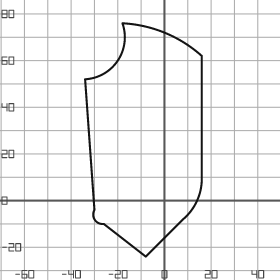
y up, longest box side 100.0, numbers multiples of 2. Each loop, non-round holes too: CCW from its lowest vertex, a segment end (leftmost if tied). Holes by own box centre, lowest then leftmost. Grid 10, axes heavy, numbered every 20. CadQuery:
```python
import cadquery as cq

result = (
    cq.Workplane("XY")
    .moveTo(-8.0, -24.0)
    .lineTo(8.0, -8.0)
    .threePointArc((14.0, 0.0), (16.0, 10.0))
    .lineTo(16.0, 62.0)
    .threePointArc((0.0, 72.0), (-18.0, 76.0))
    .threePointArc((-20.0, 60.0), (-34.0, 52.0))
    .lineTo(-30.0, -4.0)
    .threePointArc((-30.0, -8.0), (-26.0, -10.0))
    .close()
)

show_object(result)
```